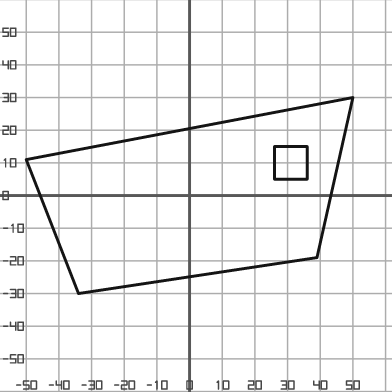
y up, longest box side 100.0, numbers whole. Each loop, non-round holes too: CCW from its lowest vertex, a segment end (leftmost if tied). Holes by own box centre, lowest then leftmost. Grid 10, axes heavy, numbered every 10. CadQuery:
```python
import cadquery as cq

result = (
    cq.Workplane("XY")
    .moveTo(-34.0, -30.0)
    .lineTo(39.0, -19.0)
    .lineTo(50.0, 30.0)
    .lineTo(-50.0, 11.0)
    .close()
    .moveTo(26.0, 5.0)
    .lineTo(36.0, 5.0)
    .lineTo(36.0, 15.0)
    .lineTo(26.0, 15.0)
    .close()
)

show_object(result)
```